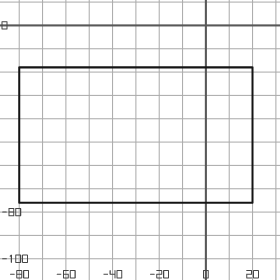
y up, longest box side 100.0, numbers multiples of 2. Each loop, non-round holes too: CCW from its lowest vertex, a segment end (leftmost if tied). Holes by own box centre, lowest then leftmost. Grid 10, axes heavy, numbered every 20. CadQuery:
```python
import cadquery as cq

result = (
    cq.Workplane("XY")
    .moveTo(-80.0, -76.0)
    .lineTo(20.0, -76.0)
    .lineTo(20.0, -18.0)
    .lineTo(-80.0, -18.0)
    .close()
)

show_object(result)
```